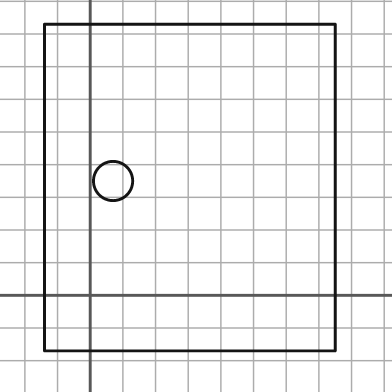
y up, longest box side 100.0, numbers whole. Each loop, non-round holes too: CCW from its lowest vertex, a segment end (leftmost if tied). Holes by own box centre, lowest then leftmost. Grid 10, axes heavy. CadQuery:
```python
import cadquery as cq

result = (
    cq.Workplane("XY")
    .moveTo(-14.0, -17.0)
    .lineTo(75.0, -17.0)
    .lineTo(75.0, 83.0)
    .lineTo(-14.0, 83.0)
    .close()
    .moveTo(7.0, 35.0)
    .circle(6.0)
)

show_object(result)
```